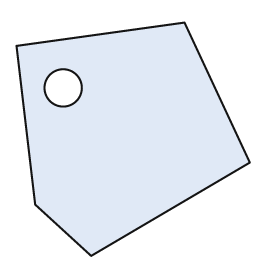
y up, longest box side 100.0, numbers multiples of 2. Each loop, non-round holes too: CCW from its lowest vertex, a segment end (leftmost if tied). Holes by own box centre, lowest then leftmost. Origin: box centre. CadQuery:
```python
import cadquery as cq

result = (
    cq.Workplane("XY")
    .moveTo(-18.0, -50.0)
    .lineTo(50.0, -10.0)
    .lineTo(22.0, 50.0)
    .lineTo(-50.0, 40.0)
    .lineTo(-42.0, -28.0)
    .close()
    .moveTo(-30.0, 22.0)
    .circle(8.0)
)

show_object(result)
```